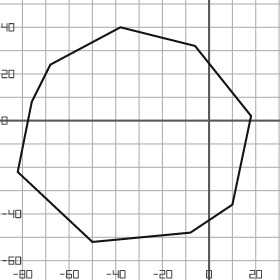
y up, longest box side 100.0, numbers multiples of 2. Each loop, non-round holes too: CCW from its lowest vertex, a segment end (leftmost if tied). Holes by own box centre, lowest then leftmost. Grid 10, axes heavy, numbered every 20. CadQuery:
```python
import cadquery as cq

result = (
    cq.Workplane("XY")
    .moveTo(-50.0, -52.0)
    .lineTo(-8.0, -48.0)
    .lineTo(10.0, -36.0)
    .lineTo(18.0, 2.0)
    .lineTo(-6.0, 32.0)
    .lineTo(-38.0, 40.0)
    .lineTo(-68.0, 24.0)
    .lineTo(-76.0, 8.0)
    .lineTo(-82.0, -22.0)
    .close()
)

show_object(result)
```